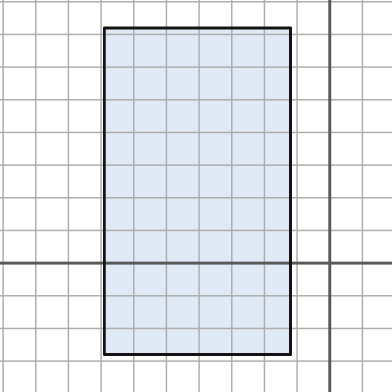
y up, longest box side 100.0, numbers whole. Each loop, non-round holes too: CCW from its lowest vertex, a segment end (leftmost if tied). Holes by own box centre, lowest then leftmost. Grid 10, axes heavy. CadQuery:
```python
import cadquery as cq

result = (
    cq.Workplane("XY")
    .moveTo(-69.0, -28.0)
    .lineTo(-12.0, -28.0)
    .lineTo(-12.0, 72.0)
    .lineTo(-69.0, 72.0)
    .close()
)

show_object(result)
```